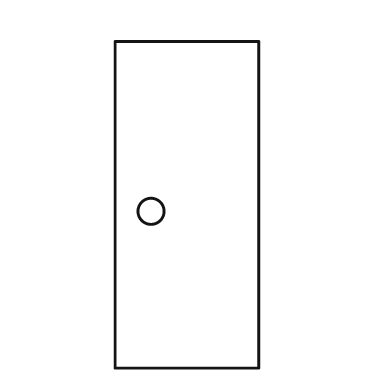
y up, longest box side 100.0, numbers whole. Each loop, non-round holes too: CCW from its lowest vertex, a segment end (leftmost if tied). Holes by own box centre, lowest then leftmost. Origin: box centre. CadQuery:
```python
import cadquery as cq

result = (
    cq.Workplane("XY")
    .moveTo(-22.0, -50.0)
    .lineTo(22.0, -50.0)
    .lineTo(22.0, 50.0)
    .lineTo(-22.0, 50.0)
    .close()
    .moveTo(-11.0, -2.0)
    .circle(4.0)
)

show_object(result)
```